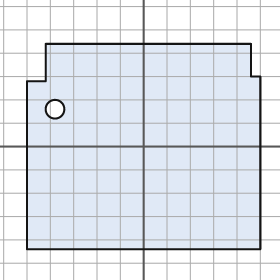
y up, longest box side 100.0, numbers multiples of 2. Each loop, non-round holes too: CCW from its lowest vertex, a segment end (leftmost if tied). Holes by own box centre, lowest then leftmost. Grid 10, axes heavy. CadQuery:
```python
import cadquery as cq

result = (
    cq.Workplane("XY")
    .moveTo(-50.0, -44.0)
    .lineTo(50.0, -44.0)
    .lineTo(50.0, 30.0)
    .lineTo(46.0, 30.0)
    .lineTo(46.0, 44.0)
    .lineTo(-42.0, 44.0)
    .lineTo(-42.0, 28.0)
    .lineTo(-50.0, 28.0)
    .close()
    .moveTo(-38.0, 16.0)
    .circle(4.0)
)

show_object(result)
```